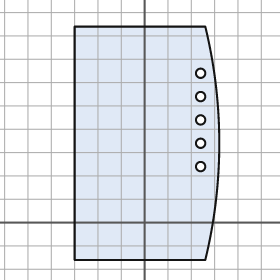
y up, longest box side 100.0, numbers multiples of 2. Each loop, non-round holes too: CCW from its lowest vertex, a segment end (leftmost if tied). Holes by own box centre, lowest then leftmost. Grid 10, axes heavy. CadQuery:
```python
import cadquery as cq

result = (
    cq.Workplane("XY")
    .moveTo(-30.0, -16.0)
    .lineTo(26.0, -16.0)
    .threePointArc((32.0, 34.0), (26.0, 84.0))
    .lineTo(-30.0, 84.0)
    .close()
    .moveTo(24.0, 24.0)
    .circle(2.0)
    .moveTo(24.0, 34.0)
    .circle(2.0)
    .moveTo(24.0, 44.0)
    .circle(2.0)
    .moveTo(24.0, 54.0)
    .circle(2.0)
    .moveTo(24.0, 64.0)
    .circle(2.0)
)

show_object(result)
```